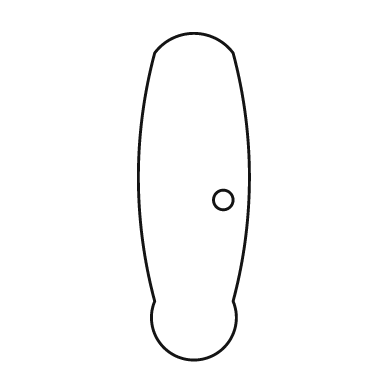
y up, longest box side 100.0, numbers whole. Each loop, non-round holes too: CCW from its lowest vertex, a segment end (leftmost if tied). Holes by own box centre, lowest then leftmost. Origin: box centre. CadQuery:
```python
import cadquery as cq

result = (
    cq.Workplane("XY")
    .moveTo(-12.0, -32.0)
    .threePointArc((0.0, -50.0), (12.0, -32.0))
    .threePointArc((17.0, 6.0), (12.0, 44.0))
    .threePointArc((0.0, 50.0), (-12.0, 44.0))
    .threePointArc((-17.0, 6.0), (-12.0, -32.0))
    .close()
    .moveTo(9.0, -1.0)
    .circle(3.0)
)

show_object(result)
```